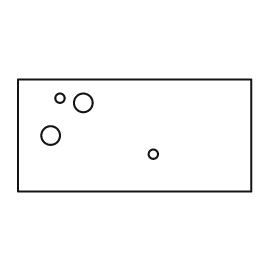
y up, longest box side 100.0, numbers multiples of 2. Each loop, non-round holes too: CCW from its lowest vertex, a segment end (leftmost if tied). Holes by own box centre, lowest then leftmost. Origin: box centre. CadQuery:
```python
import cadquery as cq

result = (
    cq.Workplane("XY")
    .moveTo(-50.0, -24.0)
    .lineTo(50.0, -24.0)
    .lineTo(50.0, 24.0)
    .lineTo(-50.0, 24.0)
    .close()
    .moveTo(8.0, -8.0)
    .circle(2.0)
    .moveTo(-36.0, 0.0)
    .circle(4.0)
    .moveTo(-22.0, 14.0)
    .circle(4.0)
    .moveTo(-32.0, 16.0)
    .circle(2.0)
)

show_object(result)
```